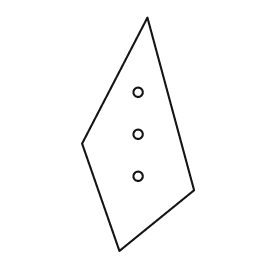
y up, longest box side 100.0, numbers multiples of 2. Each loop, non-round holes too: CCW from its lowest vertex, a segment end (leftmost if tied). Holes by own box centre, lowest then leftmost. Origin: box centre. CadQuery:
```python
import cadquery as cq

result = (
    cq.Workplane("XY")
    .moveTo(-8.0, -50.0)
    .lineTo(24.0, -24.0)
    .lineTo(4.0, 50.0)
    .lineTo(-24.0, -4.0)
    .close()
    .moveTo(0.0, -18.0)
    .circle(2.0)
    .moveTo(0.0, 0.0)
    .circle(2.0)
    .moveTo(0.0, 18.0)
    .circle(2.0)
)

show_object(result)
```